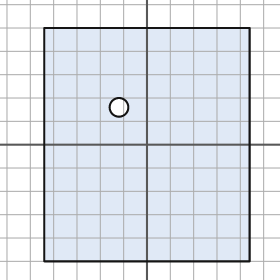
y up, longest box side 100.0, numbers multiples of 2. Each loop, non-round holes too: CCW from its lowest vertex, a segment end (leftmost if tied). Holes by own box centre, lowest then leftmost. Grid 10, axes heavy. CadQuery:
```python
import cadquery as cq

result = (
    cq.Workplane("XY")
    .moveTo(-44.0, -50.0)
    .lineTo(44.0, -50.0)
    .lineTo(44.0, 50.0)
    .lineTo(-44.0, 50.0)
    .close()
    .moveTo(-12.0, 16.0)
    .circle(4.0)
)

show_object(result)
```